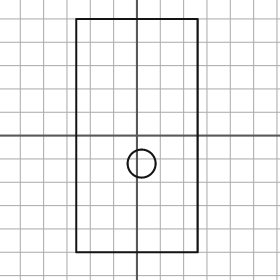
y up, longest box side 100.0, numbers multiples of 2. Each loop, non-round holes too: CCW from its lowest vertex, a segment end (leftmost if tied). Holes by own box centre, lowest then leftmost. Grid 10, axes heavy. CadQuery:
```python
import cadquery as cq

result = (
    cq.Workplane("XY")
    .moveTo(-26.0, -50.0)
    .lineTo(26.0, -50.0)
    .lineTo(26.0, 50.0)
    .lineTo(-26.0, 50.0)
    .close()
    .moveTo(2.0, -12.0)
    .circle(6.0)
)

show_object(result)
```